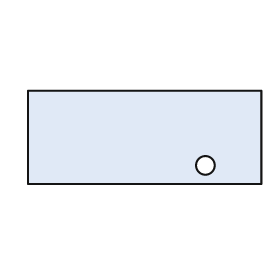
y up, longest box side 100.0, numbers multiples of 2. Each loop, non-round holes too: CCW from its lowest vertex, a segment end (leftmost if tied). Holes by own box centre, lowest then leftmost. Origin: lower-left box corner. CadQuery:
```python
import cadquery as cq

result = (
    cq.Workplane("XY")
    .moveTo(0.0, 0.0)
    .lineTo(100.0, 0.0)
    .lineTo(100.0, 40.0)
    .lineTo(0.0, 40.0)
    .close()
    .moveTo(76.0, 8.0)
    .circle(4.0)
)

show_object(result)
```